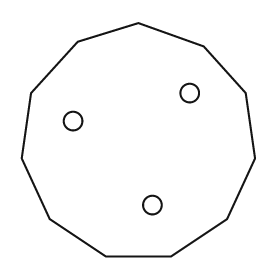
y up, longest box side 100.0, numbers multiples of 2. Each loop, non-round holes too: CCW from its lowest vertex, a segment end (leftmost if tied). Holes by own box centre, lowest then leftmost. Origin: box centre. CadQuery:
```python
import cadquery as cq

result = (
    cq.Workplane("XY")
    .moveTo(-14.0, -50.0)
    .lineTo(14.0, -50.0)
    .lineTo(38.0, -34.0)
    .lineTo(50.0, -8.0)
    .lineTo(46.0, 20.0)
    .lineTo(28.0, 40.0)
    .lineTo(0.0, 50.0)
    .lineTo(-26.0, 42.0)
    .lineTo(-46.0, 20.0)
    .lineTo(-50.0, -8.0)
    .lineTo(-38.0, -34.0)
    .close()
    .moveTo(6.0, -28.0)
    .circle(4.0)
    .moveTo(-28.0, 8.0)
    .circle(4.0)
    .moveTo(22.0, 20.0)
    .circle(4.0)
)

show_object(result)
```